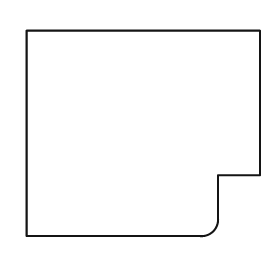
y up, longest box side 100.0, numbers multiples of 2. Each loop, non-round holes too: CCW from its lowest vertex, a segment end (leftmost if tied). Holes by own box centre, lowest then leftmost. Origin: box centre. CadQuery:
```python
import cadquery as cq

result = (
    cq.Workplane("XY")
    .moveTo(-50.0, -44.0)
    .lineTo(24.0, -44.0)
    .threePointArc((30.0, -42.0), (32.0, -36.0))
    .lineTo(32.0, -18.0)
    .lineTo(50.0, -18.0)
    .lineTo(50.0, 44.0)
    .lineTo(-50.0, 44.0)
    .close()
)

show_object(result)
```